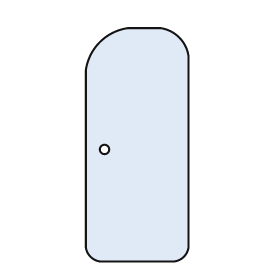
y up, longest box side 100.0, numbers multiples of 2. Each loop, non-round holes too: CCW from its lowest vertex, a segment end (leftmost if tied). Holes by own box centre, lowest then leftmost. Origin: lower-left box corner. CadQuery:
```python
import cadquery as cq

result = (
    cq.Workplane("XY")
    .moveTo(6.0, 0.0)
    .lineTo(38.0, 0.0)
    .threePointArc((42.0, 2.0), (44.0, 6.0))
    .lineTo(44.0, 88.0)
    .threePointArc((40.0, 96.0), (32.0, 100.0))
    .lineTo(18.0, 100.0)
    .threePointArc((6.0, 94.0), (0.0, 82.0))
    .lineTo(0.0, 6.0)
    .threePointArc((2.0, 2.0), (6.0, 0.0))
    .close()
    .moveTo(8.0, 48.0)
    .circle(2.0)
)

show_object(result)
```